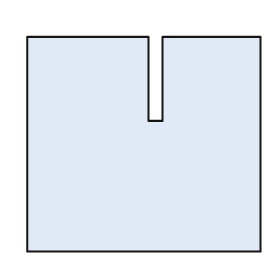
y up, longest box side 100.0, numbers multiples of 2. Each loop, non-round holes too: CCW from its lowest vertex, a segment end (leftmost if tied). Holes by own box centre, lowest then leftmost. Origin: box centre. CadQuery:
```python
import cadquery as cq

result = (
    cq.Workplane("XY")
    .moveTo(-50.0, -46.0)
    .lineTo(50.0, -46.0)
    .lineTo(50.0, 46.0)
    .lineTo(8.0, 46.0)
    .lineTo(8.0, 10.0)
    .lineTo(2.0, 10.0)
    .lineTo(2.0, 46.0)
    .lineTo(-50.0, 46.0)
    .close()
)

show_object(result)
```